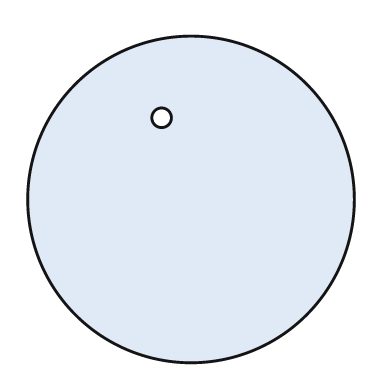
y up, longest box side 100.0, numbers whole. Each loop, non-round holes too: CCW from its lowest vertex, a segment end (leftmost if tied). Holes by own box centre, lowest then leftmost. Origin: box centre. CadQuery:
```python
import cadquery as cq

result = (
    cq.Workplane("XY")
    .moveTo(0.0, 0.0)
    .circle(50.0)
    .moveTo(-9.0, 25.0)
    .circle(3.0)
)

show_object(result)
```